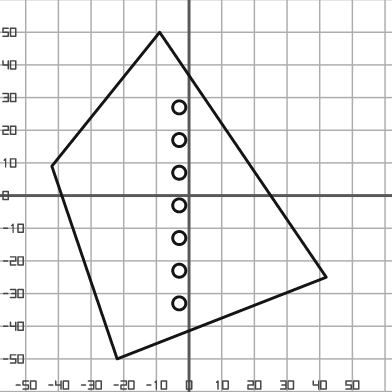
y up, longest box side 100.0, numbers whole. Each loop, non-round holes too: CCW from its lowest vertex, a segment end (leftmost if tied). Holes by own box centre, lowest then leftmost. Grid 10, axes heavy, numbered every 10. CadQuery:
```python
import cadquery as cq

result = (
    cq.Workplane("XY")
    .moveTo(-22.0, -50.0)
    .lineTo(42.0, -25.0)
    .lineTo(-9.0, 50.0)
    .lineTo(-42.0, 9.0)
    .close()
    .moveTo(-3.0, -33.0)
    .circle(2.0)
    .moveTo(-3.0, -23.0)
    .circle(2.0)
    .moveTo(-3.0, -13.0)
    .circle(2.0)
    .moveTo(-3.0, -3.0)
    .circle(2.0)
    .moveTo(-3.0, 7.0)
    .circle(2.0)
    .moveTo(-3.0, 17.0)
    .circle(2.0)
    .moveTo(-3.0, 27.0)
    .circle(2.0)
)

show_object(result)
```